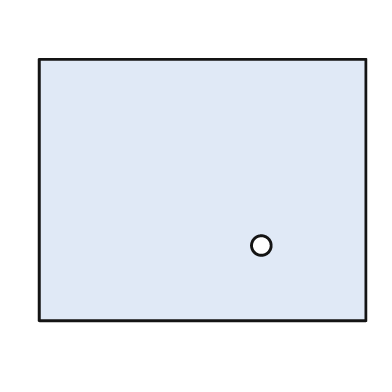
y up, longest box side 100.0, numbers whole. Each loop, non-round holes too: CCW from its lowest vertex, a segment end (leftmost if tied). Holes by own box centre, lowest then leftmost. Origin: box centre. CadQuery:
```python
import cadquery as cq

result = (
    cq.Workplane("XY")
    .moveTo(-50.0, -40.0)
    .lineTo(50.0, -40.0)
    .lineTo(50.0, 40.0)
    .lineTo(-50.0, 40.0)
    .close()
    .moveTo(18.0, -17.0)
    .circle(3.0)
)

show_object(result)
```